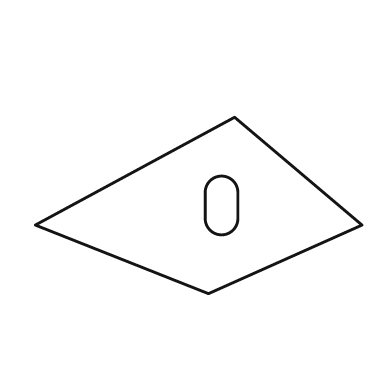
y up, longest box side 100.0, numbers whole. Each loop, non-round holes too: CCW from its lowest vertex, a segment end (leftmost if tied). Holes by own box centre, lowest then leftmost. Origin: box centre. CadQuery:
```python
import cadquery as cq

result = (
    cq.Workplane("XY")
    .moveTo(3.0, -27.0)
    .lineTo(50.0, -6.0)
    .lineTo(11.0, 27.0)
    .lineTo(-50.0, -6.0)
    .close()
    .moveTo(2.0, -4.0)
    .threePointArc((7.0, -9.0), (12.0, -4.0))
    .lineTo(12.0, 4.0)
    .threePointArc((7.0, 9.0), (2.0, 4.0))
    .close()
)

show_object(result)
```